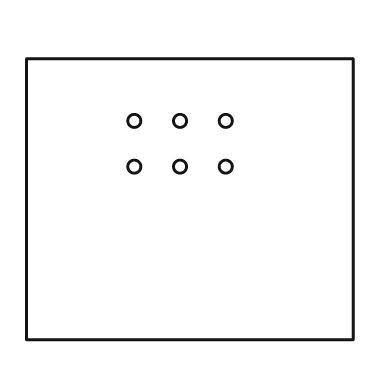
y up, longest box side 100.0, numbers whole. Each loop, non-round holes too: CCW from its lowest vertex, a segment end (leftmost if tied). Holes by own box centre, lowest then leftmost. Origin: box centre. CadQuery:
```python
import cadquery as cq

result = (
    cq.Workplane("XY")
    .moveTo(-50.0, -43.0)
    .lineTo(50.0, -43.0)
    .lineTo(50.0, 43.0)
    .lineTo(-50.0, 43.0)
    .close()
    .moveTo(-17.0, 10.0)
    .circle(2.0)
    .moveTo(-3.0, 10.0)
    .circle(2.0)
    .moveTo(11.0, 10.0)
    .circle(2.0)
    .moveTo(-17.0, 24.0)
    .circle(2.0)
    .moveTo(-3.0, 24.0)
    .circle(2.0)
    .moveTo(11.0, 24.0)
    .circle(2.0)
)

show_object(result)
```